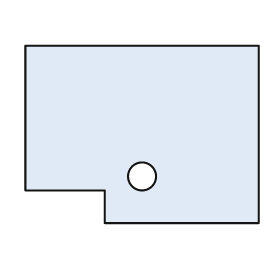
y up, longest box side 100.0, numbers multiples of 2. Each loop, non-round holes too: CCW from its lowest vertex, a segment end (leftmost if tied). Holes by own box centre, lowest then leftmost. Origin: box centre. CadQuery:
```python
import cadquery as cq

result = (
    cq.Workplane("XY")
    .moveTo(-16.0, -38.0)
    .lineTo(50.0, -38.0)
    .lineTo(50.0, 38.0)
    .lineTo(-50.0, 38.0)
    .lineTo(-50.0, -24.0)
    .lineTo(-16.0, -24.0)
    .close()
    .moveTo(0.0, -18.0)
    .circle(6.0)
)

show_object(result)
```